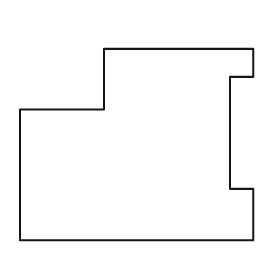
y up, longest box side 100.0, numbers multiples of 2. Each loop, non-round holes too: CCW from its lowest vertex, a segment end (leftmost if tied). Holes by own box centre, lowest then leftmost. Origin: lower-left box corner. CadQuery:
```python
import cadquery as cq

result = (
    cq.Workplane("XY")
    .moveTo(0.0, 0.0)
    .lineTo(100.0, 0.0)
    .lineTo(100.0, 22.0)
    .lineTo(90.0, 22.0)
    .lineTo(90.0, 70.0)
    .lineTo(100.0, 70.0)
    .lineTo(100.0, 82.0)
    .lineTo(36.0, 82.0)
    .lineTo(36.0, 56.0)
    .lineTo(0.0, 56.0)
    .close()
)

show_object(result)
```